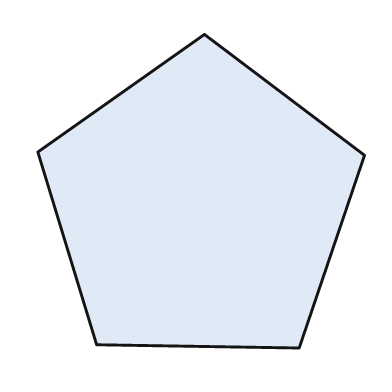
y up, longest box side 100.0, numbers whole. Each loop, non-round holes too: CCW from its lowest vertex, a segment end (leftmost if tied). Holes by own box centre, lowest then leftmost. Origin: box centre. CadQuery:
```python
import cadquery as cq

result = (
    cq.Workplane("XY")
    .moveTo(30.0, -48.0)
    .lineTo(50.0, 11.0)
    .lineTo(1.0, 48.0)
    .lineTo(-50.0, 12.0)
    .lineTo(-32.0, -47.0)
    .close()
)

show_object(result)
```